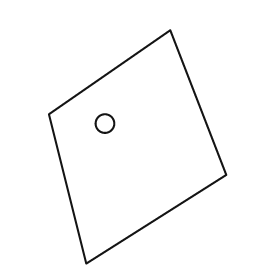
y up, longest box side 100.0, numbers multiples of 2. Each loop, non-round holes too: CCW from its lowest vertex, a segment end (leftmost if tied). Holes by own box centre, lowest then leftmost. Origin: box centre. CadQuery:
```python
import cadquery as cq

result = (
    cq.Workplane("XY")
    .moveTo(-22.0, -50.0)
    .lineTo(38.0, -12.0)
    .lineTo(14.0, 50.0)
    .lineTo(-38.0, 14.0)
    .close()
    .moveTo(-14.0, 10.0)
    .circle(4.0)
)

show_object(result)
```